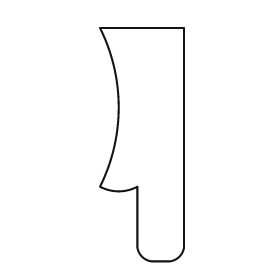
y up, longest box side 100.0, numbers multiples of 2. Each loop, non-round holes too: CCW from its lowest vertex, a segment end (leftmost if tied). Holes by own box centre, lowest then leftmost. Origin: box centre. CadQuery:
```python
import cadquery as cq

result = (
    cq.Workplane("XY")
    .moveTo(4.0, -50.0)
    .lineTo(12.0, -50.0)
    .threePointArc((16.0, -48.0), (18.0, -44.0))
    .lineTo(18.0, 50.0)
    .lineTo(-18.0, 50.0)
    .threePointArc((-10.0, 16.0), (-18.0, -18.0))
    .threePointArc((-10.0, -20.0), (-2.0, -18.0))
    .lineTo(-2.0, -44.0)
    .threePointArc((0.0, -48.0), (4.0, -50.0))
    .close()
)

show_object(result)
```